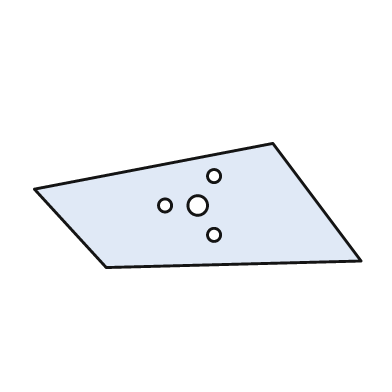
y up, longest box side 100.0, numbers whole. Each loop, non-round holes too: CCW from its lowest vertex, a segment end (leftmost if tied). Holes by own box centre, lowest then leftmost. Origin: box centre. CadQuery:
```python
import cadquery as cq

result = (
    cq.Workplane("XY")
    .moveTo(-28.0, -19.0)
    .lineTo(50.0, -17.0)
    .lineTo(23.0, 19.0)
    .lineTo(-50.0, 5.0)
    .close()
    .moveTo(5.0, -9.0)
    .circle(2.0)
    .moveTo(-10.0, 0.0)
    .circle(2.0)
    .moveTo(0.0, 0.0)
    .circle(3.0)
    .moveTo(5.0, 9.0)
    .circle(2.0)
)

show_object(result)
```